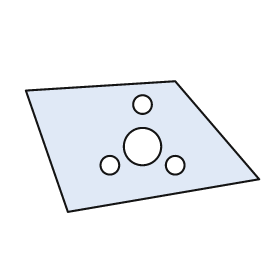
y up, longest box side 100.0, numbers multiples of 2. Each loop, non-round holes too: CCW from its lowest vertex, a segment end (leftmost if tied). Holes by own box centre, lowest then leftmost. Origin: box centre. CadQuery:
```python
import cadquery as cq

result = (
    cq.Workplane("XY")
    .moveTo(-32.0, -28.0)
    .lineTo(50.0, -14.0)
    .lineTo(14.0, 28.0)
    .lineTo(-50.0, 24.0)
    .close()
    .moveTo(-14.0, -8.0)
    .circle(4.0)
    .moveTo(14.0, -8.0)
    .circle(4.0)
    .moveTo(0.0, 0.0)
    .circle(8.0)
    .moveTo(0.0, 18.0)
    .circle(4.0)
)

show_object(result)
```